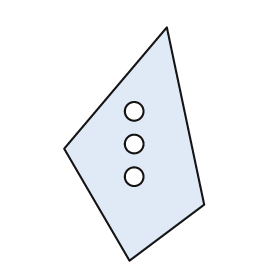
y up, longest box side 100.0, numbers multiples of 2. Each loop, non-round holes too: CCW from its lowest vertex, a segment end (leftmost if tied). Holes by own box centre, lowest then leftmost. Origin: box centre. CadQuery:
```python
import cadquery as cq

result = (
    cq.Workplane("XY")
    .moveTo(-2.0, -50.0)
    .lineTo(30.0, -26.0)
    .lineTo(14.0, 50.0)
    .lineTo(-30.0, -2.0)
    .close()
    .moveTo(0.0, -14.0)
    .circle(4.0)
    .moveTo(0.0, 0.0)
    .circle(4.0)
    .moveTo(0.0, 14.0)
    .circle(4.0)
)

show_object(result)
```